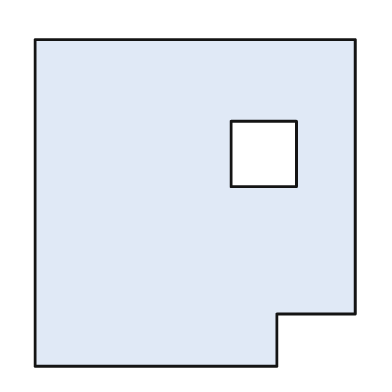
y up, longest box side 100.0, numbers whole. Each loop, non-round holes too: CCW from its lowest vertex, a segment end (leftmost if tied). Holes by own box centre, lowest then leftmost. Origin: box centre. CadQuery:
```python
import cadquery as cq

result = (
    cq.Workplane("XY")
    .moveTo(-49.0, -50.0)
    .lineTo(25.0, -50.0)
    .lineTo(25.0, -34.0)
    .lineTo(49.0, -34.0)
    .lineTo(49.0, 50.0)
    .lineTo(-49.0, 50.0)
    .close()
    .moveTo(11.0, 5.0)
    .lineTo(31.0, 5.0)
    .lineTo(31.0, 25.0)
    .lineTo(11.0, 25.0)
    .close()
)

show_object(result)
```